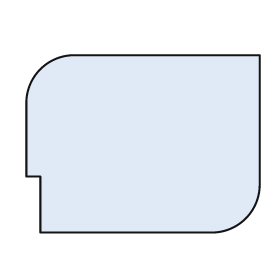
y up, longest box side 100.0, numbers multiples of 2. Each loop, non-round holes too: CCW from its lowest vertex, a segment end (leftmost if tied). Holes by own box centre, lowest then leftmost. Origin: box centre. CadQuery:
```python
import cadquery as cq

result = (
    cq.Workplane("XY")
    .moveTo(-44.0, -38.0)
    .lineTo(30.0, -38.0)
    .threePointArc((44.0, -32.0), (50.0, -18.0))
    .lineTo(50.0, 38.0)
    .lineTo(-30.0, 38.0)
    .threePointArc((-44.0, 32.0), (-50.0, 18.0))
    .lineTo(-50.0, -14.0)
    .lineTo(-44.0, -14.0)
    .close()
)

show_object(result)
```